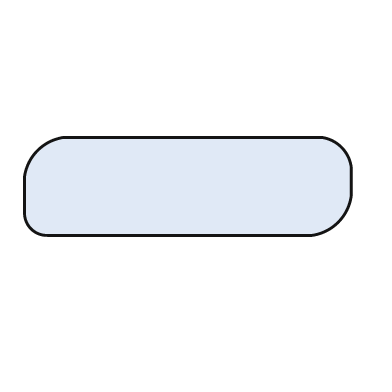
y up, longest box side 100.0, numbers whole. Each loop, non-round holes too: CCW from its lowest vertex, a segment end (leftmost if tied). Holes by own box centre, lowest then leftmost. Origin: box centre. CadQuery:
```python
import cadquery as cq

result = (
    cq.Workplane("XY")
    .moveTo(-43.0, -15.0)
    .lineTo(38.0, -15.0)
    .threePointArc((46.0, -11.0), (50.0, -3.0))
    .lineTo(50.0, 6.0)
    .threePointArc((47.0, 12.0), (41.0, 15.0))
    .lineTo(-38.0, 15.0)
    .threePointArc((-46.0, 11.0), (-50.0, 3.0))
    .lineTo(-50.0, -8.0)
    .threePointArc((-48.0, -13.0), (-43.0, -15.0))
    .close()
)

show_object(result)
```